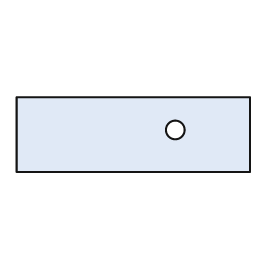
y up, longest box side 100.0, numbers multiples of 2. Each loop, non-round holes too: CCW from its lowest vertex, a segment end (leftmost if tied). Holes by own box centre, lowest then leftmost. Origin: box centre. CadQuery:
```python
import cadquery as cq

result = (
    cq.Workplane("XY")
    .moveTo(-50.0, -16.0)
    .lineTo(50.0, -16.0)
    .lineTo(50.0, 16.0)
    .lineTo(-50.0, 16.0)
    .close()
    .moveTo(18.0, 2.0)
    .circle(4.0)
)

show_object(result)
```